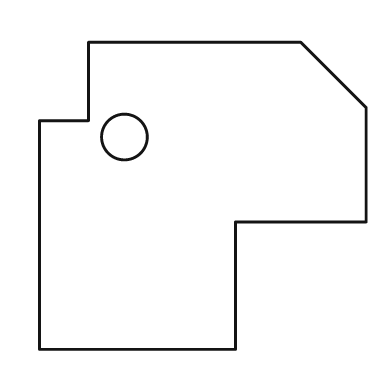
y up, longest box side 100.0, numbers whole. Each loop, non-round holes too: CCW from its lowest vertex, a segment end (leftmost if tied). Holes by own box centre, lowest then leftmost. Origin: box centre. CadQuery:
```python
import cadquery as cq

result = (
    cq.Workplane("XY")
    .moveTo(-50.0, -47.0)
    .lineTo(10.0, -47.0)
    .lineTo(10.0, -8.0)
    .lineTo(50.0, -8.0)
    .lineTo(50.0, 27.0)
    .lineTo(30.0, 47.0)
    .lineTo(-35.0, 47.0)
    .lineTo(-35.0, 23.0)
    .lineTo(-50.0, 23.0)
    .close()
    .moveTo(-24.0, 18.0)
    .circle(7.0)
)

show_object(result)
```